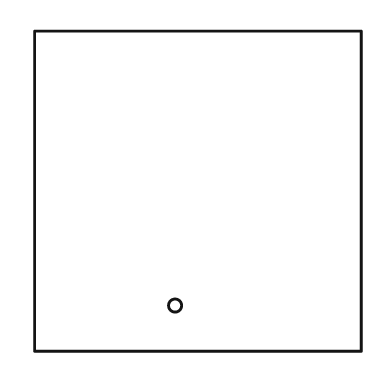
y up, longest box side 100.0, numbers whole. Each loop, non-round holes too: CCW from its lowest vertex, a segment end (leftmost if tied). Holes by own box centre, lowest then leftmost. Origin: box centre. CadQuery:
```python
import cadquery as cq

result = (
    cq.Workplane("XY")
    .moveTo(-50.0, -49.0)
    .lineTo(50.0, -49.0)
    .lineTo(50.0, 49.0)
    .lineTo(-50.0, 49.0)
    .close()
    .moveTo(-7.0, -35.0)
    .circle(2.0)
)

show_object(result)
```